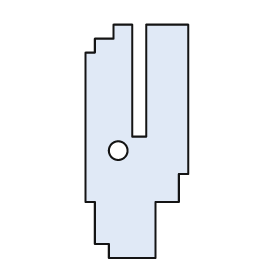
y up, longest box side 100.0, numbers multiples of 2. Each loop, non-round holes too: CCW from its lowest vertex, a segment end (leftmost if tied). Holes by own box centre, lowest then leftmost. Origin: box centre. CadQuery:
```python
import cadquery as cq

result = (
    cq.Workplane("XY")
    .moveTo(-12.0, -50.0)
    .lineTo(8.0, -50.0)
    .lineTo(8.0, -26.0)
    .lineTo(18.0, -26.0)
    .lineTo(18.0, -14.0)
    .lineTo(22.0, -14.0)
    .lineTo(22.0, 50.0)
    .lineTo(4.0, 50.0)
    .lineTo(4.0, 2.0)
    .lineTo(-2.0, 2.0)
    .lineTo(-2.0, 50.0)
    .lineTo(-10.0, 50.0)
    .lineTo(-10.0, 44.0)
    .lineTo(-18.0, 44.0)
    .lineTo(-18.0, 38.0)
    .lineTo(-22.0, 38.0)
    .lineTo(-22.0, -26.0)
    .lineTo(-18.0, -26.0)
    .lineTo(-18.0, -44.0)
    .lineTo(-12.0, -44.0)
    .close()
    .moveTo(-8.0, -4.0)
    .circle(4.0)
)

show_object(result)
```